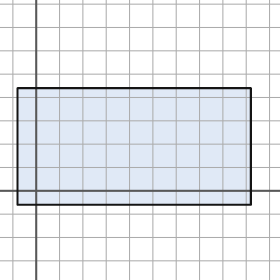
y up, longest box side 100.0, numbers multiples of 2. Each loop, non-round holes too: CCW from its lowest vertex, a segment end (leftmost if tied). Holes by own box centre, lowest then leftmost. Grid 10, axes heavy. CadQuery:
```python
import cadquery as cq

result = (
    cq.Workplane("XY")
    .moveTo(-8.0, -6.0)
    .lineTo(92.0, -6.0)
    .lineTo(92.0, 44.0)
    .lineTo(-8.0, 44.0)
    .close()
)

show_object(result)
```